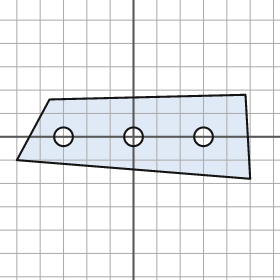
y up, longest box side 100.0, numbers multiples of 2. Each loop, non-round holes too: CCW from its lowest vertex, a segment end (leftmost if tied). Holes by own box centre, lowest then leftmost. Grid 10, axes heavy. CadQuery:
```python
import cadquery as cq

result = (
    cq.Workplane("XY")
    .moveTo(50.0, -18.0)
    .lineTo(48.0, 18.0)
    .lineTo(-36.0, 16.0)
    .lineTo(-50.0, -10.0)
    .close()
    .moveTo(-30.0, 0.0)
    .circle(4.0)
    .moveTo(0.0, 0.0)
    .circle(4.0)
    .moveTo(30.0, 0.0)
    .circle(4.0)
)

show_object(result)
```